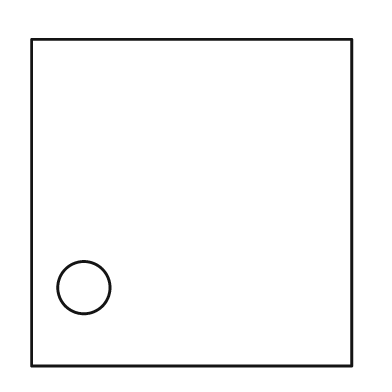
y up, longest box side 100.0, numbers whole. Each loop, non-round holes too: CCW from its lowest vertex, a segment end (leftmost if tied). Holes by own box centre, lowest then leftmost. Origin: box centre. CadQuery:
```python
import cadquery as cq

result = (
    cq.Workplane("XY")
    .moveTo(-49.0, -50.0)
    .lineTo(49.0, -50.0)
    .lineTo(49.0, 50.0)
    .lineTo(-49.0, 50.0)
    .close()
    .moveTo(-33.0, -26.0)
    .circle(8.0)
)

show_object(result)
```